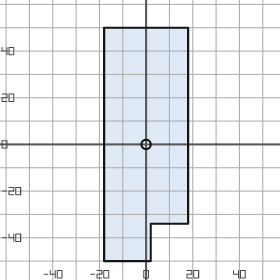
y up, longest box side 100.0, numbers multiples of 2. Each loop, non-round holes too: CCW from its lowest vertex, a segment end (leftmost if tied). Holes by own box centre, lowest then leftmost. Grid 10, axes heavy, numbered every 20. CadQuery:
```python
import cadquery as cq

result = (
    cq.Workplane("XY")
    .moveTo(-18.0, -50.0)
    .lineTo(2.0, -50.0)
    .lineTo(2.0, -34.0)
    .lineTo(18.0, -34.0)
    .lineTo(18.0, 50.0)
    .lineTo(-18.0, 50.0)
    .close()
    .moveTo(0.0, 0.0)
    .circle(2.0)
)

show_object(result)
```